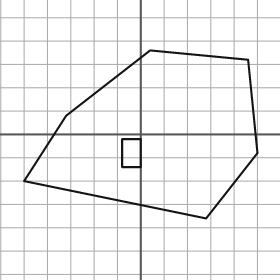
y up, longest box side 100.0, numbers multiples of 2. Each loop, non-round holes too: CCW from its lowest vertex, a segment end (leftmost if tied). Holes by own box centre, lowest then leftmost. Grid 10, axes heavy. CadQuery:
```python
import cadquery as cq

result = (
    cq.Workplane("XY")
    .moveTo(28.0, -36.0)
    .lineTo(50.0, -8.0)
    .lineTo(46.0, 32.0)
    .lineTo(4.0, 36.0)
    .lineTo(-32.0, 8.0)
    .lineTo(-50.0, -20.0)
    .close()
    .moveTo(-8.0, -14.0)
    .lineTo(0.0, -14.0)
    .lineTo(0.0, -2.0)
    .lineTo(-8.0, -2.0)
    .close()
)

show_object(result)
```